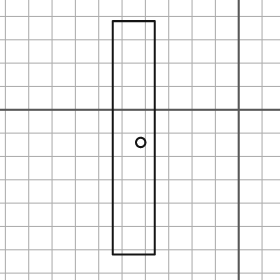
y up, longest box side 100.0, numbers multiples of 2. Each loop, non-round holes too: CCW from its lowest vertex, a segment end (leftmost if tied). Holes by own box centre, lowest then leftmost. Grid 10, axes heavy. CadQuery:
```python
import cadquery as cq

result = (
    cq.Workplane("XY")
    .moveTo(-54.0, -62.0)
    .lineTo(-36.0, -62.0)
    .lineTo(-36.0, 38.0)
    .lineTo(-54.0, 38.0)
    .close()
    .moveTo(-42.0, -14.0)
    .circle(2.0)
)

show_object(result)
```